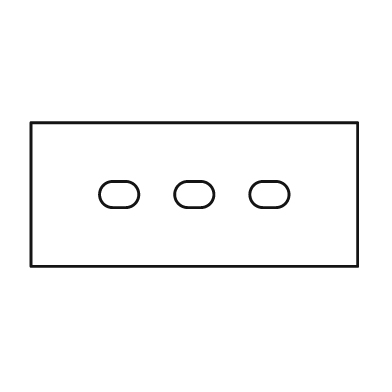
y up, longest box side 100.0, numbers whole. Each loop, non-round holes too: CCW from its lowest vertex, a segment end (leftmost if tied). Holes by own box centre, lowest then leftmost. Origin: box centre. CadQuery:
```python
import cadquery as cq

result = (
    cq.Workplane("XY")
    .moveTo(-50.0, -22.0)
    .lineTo(50.0, -22.0)
    .lineTo(50.0, 22.0)
    .lineTo(-50.0, 22.0)
    .close()
    .moveTo(-25.0, -4.0)
    .lineTo(-21.0, -4.0)
    .threePointArc((-17.0, 0.0), (-21.0, 4.0))
    .lineTo(-25.0, 4.0)
    .threePointArc((-29.0, 0.0), (-25.0, -4.0))
    .close()
    .moveTo(-2.0, -4.0)
    .lineTo(2.0, -4.0)
    .threePointArc((6.0, 0.0), (2.0, 4.0))
    .lineTo(-2.0, 4.0)
    .threePointArc((-6.0, 0.0), (-2.0, -4.0))
    .close()
    .moveTo(21.0, -4.0)
    .lineTo(25.0, -4.0)
    .threePointArc((29.0, 0.0), (25.0, 4.0))
    .lineTo(21.0, 4.0)
    .threePointArc((17.0, 0.0), (21.0, -4.0))
    .close()
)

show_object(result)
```